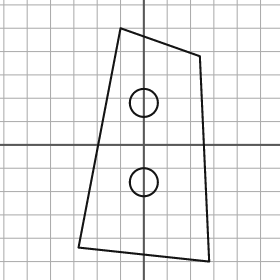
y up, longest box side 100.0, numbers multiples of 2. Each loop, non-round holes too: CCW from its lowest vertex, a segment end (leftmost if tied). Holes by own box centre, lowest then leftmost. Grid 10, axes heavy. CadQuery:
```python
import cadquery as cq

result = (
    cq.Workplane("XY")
    .moveTo(28.0, -50.0)
    .lineTo(24.0, 38.0)
    .lineTo(-10.0, 50.0)
    .lineTo(-28.0, -44.0)
    .close()
    .moveTo(0.0, -16.0)
    .circle(6.0)
    .moveTo(0.0, 18.0)
    .circle(6.0)
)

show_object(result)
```